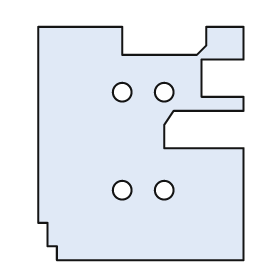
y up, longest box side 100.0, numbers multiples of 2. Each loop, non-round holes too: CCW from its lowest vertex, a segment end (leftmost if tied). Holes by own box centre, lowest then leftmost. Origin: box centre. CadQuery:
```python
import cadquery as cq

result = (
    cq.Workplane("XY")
    .moveTo(-36.0, -50.0)
    .lineTo(44.0, -50.0)
    .lineTo(44.0, -2.0)
    .lineTo(10.0, -2.0)
    .lineTo(10.0, 8.0)
    .lineTo(14.0, 14.0)
    .lineTo(44.0, 14.0)
    .lineTo(44.0, 20.0)
    .lineTo(26.0, 20.0)
    .lineTo(26.0, 36.0)
    .lineTo(44.0, 36.0)
    .lineTo(44.0, 50.0)
    .lineTo(28.0, 50.0)
    .lineTo(28.0, 42.0)
    .lineTo(24.0, 38.0)
    .lineTo(-8.0, 38.0)
    .lineTo(-8.0, 50.0)
    .lineTo(-44.0, 50.0)
    .lineTo(-44.0, -34.0)
    .lineTo(-40.0, -34.0)
    .lineTo(-40.0, -44.0)
    .lineTo(-36.0, -44.0)
    .close()
    .moveTo(-8.0, -20.0)
    .circle(4.0)
    .moveTo(10.0, -20.0)
    .circle(4.0)
    .moveTo(-8.0, 22.0)
    .circle(4.0)
    .moveTo(10.0, 22.0)
    .circle(4.0)
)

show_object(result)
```